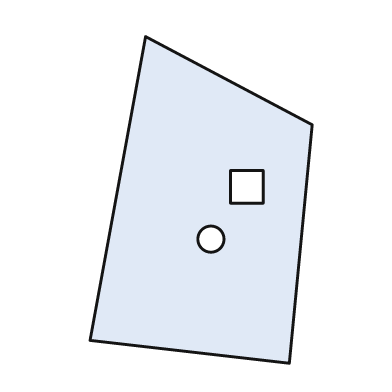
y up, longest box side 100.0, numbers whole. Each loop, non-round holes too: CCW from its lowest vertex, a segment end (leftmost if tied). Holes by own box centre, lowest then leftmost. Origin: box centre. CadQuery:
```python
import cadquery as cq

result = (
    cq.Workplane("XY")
    .moveTo(27.0, -50.0)
    .lineTo(34.0, 23.0)
    .lineTo(-17.0, 50.0)
    .lineTo(-34.0, -43.0)
    .close()
    .moveTo(3.0, -12.0)
    .circle(4.0)
    .moveTo(9.0, -1.0)
    .lineTo(19.0, -1.0)
    .lineTo(19.0, 9.0)
    .lineTo(9.0, 9.0)
    .close()
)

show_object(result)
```